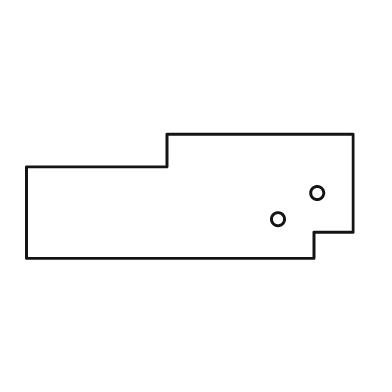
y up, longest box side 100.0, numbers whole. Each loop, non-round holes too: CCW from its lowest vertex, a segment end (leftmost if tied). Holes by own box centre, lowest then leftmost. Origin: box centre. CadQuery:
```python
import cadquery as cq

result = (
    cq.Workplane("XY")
    .moveTo(-50.0, -19.0)
    .lineTo(38.0, -19.0)
    .lineTo(38.0, -11.0)
    .lineTo(50.0, -11.0)
    .lineTo(50.0, 19.0)
    .lineTo(-7.0, 19.0)
    .lineTo(-7.0, 9.0)
    .lineTo(-50.0, 9.0)
    .close()
    .moveTo(27.0, -7.0)
    .circle(2.0)
    .moveTo(39.0, 1.0)
    .circle(2.0)
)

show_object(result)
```